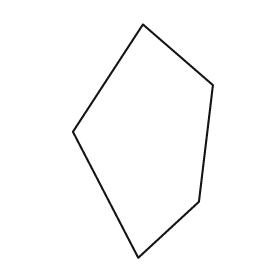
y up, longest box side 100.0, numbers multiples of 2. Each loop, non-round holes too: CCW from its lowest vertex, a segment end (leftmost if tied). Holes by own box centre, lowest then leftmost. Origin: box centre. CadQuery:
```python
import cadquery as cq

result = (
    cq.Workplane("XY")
    .moveTo(-2.0, -50.0)
    .lineTo(24.0, -26.0)
    .lineTo(30.0, 24.0)
    .lineTo(0.0, 50.0)
    .lineTo(-30.0, 4.0)
    .close()
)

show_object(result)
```